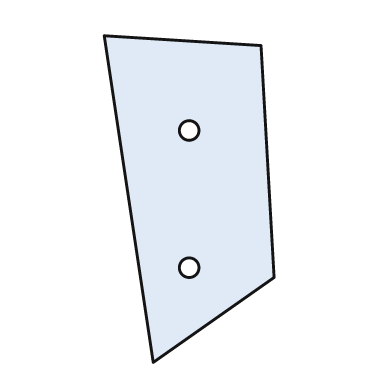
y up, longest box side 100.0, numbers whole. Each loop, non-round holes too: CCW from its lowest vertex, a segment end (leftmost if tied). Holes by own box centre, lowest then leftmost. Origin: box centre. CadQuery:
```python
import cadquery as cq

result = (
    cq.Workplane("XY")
    .moveTo(-11.0, -50.0)
    .lineTo(26.0, -24.0)
    .lineTo(22.0, 47.0)
    .lineTo(-26.0, 50.0)
    .close()
    .moveTo(0.0, -21.0)
    .circle(3.0)
    .moveTo(0.0, 21.0)
    .circle(3.0)
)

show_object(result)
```